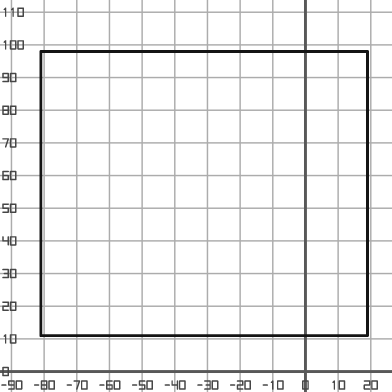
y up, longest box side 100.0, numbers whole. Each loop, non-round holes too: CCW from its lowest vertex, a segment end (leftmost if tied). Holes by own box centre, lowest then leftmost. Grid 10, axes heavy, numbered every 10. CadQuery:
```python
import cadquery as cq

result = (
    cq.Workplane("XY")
    .moveTo(-81.0, 11.0)
    .lineTo(19.0, 11.0)
    .lineTo(19.0, 98.0)
    .lineTo(-81.0, 98.0)
    .close()
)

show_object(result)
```